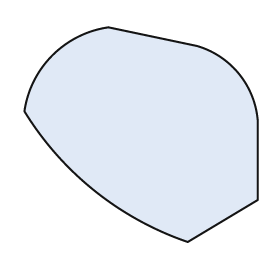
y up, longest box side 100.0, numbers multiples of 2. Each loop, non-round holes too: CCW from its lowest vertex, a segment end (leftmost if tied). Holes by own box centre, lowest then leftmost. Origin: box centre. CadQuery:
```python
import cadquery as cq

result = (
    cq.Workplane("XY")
    .moveTo(20.0, -46.0)
    .lineTo(50.0, -28.0)
    .lineTo(50.0, 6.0)
    .threePointArc((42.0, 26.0), (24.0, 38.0))
    .lineTo(-14.0, 46.0)
    .threePointArc((-38.0, 34.0), (-50.0, 10.0))
    .threePointArc((-20.0, -24.0), (20.0, -46.0))
    .close()
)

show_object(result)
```